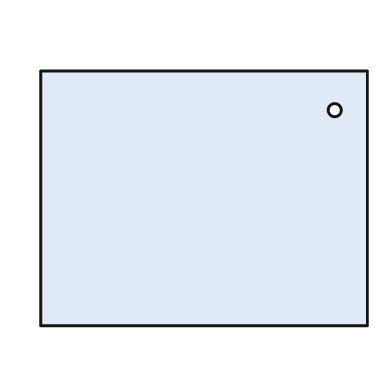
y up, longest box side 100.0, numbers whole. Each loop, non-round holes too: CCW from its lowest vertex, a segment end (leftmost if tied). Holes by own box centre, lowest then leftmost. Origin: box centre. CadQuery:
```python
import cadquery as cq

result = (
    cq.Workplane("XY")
    .moveTo(-50.0, -39.0)
    .lineTo(50.0, -39.0)
    .lineTo(50.0, 39.0)
    .lineTo(-50.0, 39.0)
    .close()
    .moveTo(40.0, 27.0)
    .circle(2.0)
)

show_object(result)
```